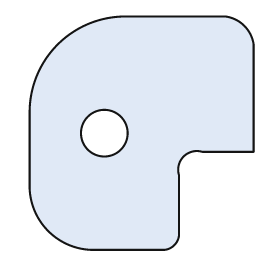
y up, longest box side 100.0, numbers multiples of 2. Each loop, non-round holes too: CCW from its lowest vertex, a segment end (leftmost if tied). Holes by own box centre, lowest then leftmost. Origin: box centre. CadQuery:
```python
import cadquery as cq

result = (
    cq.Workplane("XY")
    .moveTo(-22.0, -50.0)
    .lineTo(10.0, -50.0)
    .threePointArc((14.0, -48.0), (16.0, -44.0))
    .lineTo(16.0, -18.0)
    .threePointArc((18.0, -10.0), (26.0, -8.0))
    .lineTo(48.0, -8.0)
    .lineTo(48.0, 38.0)
    .threePointArc((44.0, 46.0), (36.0, 50.0))
    .lineTo(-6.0, 50.0)
    .threePointArc((-36.0, 38.0), (-48.0, 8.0))
    .lineTo(-48.0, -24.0)
    .threePointArc((-40.0, -42.0), (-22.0, -50.0))
    .close()
    .moveTo(-16.0, 0.0)
    .circle(10.0)
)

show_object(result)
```